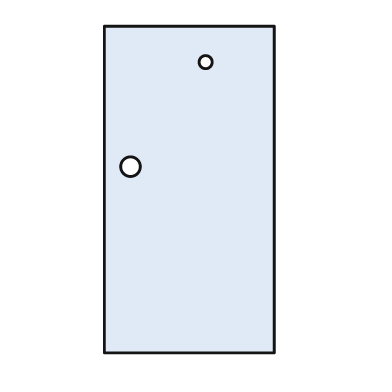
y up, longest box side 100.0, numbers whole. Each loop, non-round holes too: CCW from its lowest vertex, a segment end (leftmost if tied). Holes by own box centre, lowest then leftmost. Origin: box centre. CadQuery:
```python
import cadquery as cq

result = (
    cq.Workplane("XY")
    .moveTo(-26.0, -50.0)
    .lineTo(26.0, -50.0)
    .lineTo(26.0, 50.0)
    .lineTo(-26.0, 50.0)
    .close()
    .moveTo(-18.0, 7.0)
    .circle(3.0)
    .moveTo(5.0, 39.0)
    .circle(2.0)
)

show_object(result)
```